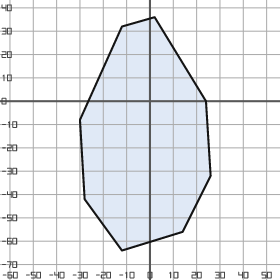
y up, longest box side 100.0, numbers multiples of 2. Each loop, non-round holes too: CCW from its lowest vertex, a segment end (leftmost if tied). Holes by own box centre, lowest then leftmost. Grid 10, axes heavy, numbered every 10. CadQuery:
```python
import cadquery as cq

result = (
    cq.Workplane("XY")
    .moveTo(-12.0, -64.0)
    .lineTo(14.0, -56.0)
    .lineTo(26.0, -32.0)
    .lineTo(24.0, 0.0)
    .lineTo(2.0, 36.0)
    .lineTo(-12.0, 32.0)
    .lineTo(-30.0, -8.0)
    .lineTo(-28.0, -42.0)
    .close()
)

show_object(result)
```